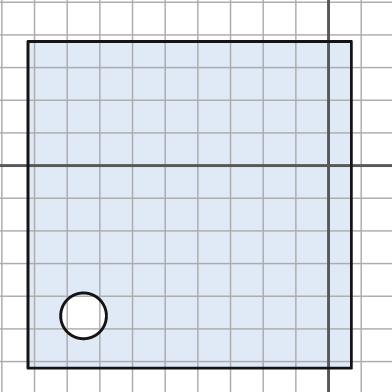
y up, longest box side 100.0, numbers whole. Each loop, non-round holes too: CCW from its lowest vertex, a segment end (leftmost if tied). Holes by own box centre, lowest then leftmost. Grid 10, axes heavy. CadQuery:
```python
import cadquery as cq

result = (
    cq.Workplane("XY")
    .moveTo(-92.0, -62.0)
    .lineTo(7.0, -62.0)
    .lineTo(7.0, 38.0)
    .lineTo(-92.0, 38.0)
    .close()
    .moveTo(-75.0, -46.0)
    .circle(7.0)
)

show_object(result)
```